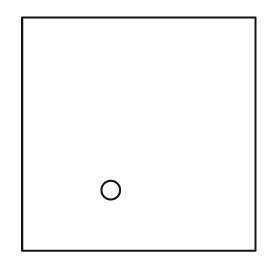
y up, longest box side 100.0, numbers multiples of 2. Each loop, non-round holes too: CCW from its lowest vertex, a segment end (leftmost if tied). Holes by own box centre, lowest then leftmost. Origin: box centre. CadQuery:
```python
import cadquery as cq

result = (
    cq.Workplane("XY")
    .moveTo(-50.0, -50.0)
    .lineTo(50.0, -50.0)
    .lineTo(50.0, 50.0)
    .lineTo(-50.0, 50.0)
    .close()
    .moveTo(-12.0, -24.0)
    .circle(4.0)
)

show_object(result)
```